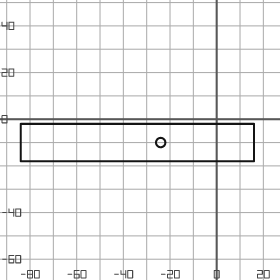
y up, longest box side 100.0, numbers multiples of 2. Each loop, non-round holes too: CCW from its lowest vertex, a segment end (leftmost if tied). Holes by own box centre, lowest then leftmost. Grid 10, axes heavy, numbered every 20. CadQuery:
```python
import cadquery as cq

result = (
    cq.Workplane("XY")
    .moveTo(-84.0, -18.0)
    .lineTo(16.0, -18.0)
    .lineTo(16.0, -2.0)
    .lineTo(-84.0, -2.0)
    .close()
    .moveTo(-24.0, -10.0)
    .circle(2.0)
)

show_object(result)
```